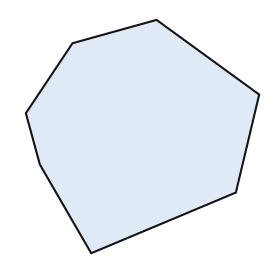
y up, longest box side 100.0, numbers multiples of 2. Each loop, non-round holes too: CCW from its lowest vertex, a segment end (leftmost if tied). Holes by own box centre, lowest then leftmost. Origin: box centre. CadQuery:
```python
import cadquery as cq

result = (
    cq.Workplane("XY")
    .moveTo(-22.0, -50.0)
    .lineTo(40.0, -24.0)
    .lineTo(50.0, 18.0)
    .lineTo(6.0, 50.0)
    .lineTo(-30.0, 40.0)
    .lineTo(-50.0, 10.0)
    .lineTo(-44.0, -12.0)
    .close()
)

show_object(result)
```